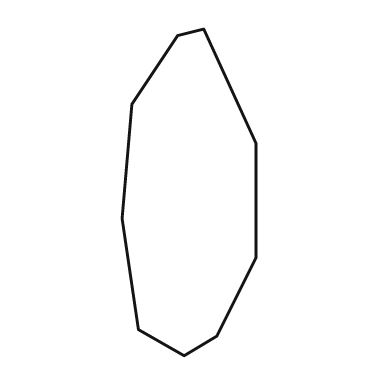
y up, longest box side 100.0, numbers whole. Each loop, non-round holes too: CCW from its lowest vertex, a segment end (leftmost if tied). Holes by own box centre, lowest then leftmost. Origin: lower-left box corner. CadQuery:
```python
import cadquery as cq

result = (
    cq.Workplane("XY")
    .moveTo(19.0, 0.0)
    .lineTo(29.0, 6.0)
    .lineTo(41.0, 30.0)
    .lineTo(41.0, 65.0)
    .lineTo(25.0, 100.0)
    .lineTo(17.0, 98.0)
    .lineTo(3.0, 77.0)
    .lineTo(0.0, 42.0)
    .lineTo(5.0, 8.0)
    .close()
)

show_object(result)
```